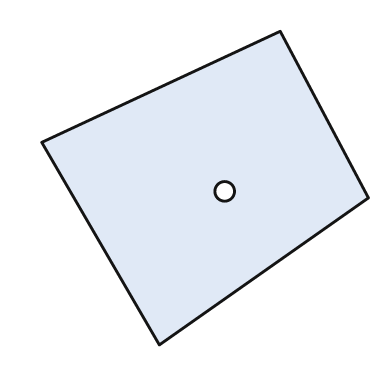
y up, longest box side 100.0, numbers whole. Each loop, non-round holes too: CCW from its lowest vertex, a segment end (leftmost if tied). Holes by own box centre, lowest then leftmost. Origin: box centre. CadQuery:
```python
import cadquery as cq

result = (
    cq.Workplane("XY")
    .moveTo(-14.0, -48.0)
    .lineTo(50.0, -3.0)
    .lineTo(23.0, 48.0)
    .lineTo(-50.0, 14.0)
    .close()
    .moveTo(6.0, -1.0)
    .circle(3.0)
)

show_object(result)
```